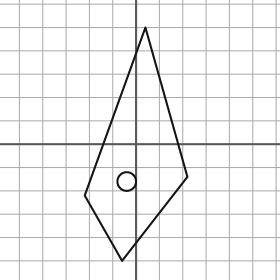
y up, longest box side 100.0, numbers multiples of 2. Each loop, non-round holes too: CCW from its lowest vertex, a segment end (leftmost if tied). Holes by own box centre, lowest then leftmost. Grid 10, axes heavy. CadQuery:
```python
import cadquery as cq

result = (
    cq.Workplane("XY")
    .moveTo(-6.0, -50.0)
    .lineTo(22.0, -14.0)
    .lineTo(4.0, 50.0)
    .lineTo(-22.0, -22.0)
    .close()
    .moveTo(-4.0, -16.0)
    .circle(4.0)
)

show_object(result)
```